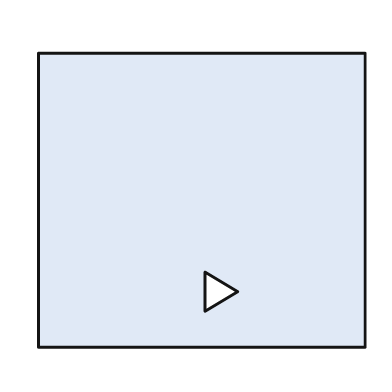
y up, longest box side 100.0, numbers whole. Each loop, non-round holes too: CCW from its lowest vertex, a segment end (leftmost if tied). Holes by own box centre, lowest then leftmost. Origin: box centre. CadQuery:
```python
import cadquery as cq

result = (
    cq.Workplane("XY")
    .moveTo(-50.0, -45.0)
    .lineTo(50.0, -45.0)
    .lineTo(50.0, 45.0)
    .lineTo(-50.0, 45.0)
    .close()
    .moveTo(1.0, -34.0)
    .lineTo(11.0, -28.0)
    .lineTo(1.0, -22.0)
    .close()
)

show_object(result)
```